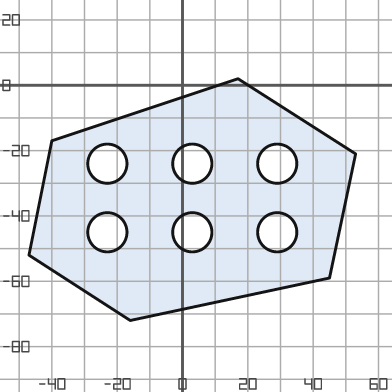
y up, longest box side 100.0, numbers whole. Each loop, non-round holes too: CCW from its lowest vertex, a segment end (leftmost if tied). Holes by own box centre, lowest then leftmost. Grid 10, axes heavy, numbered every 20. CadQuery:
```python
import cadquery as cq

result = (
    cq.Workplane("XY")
    .moveTo(-16.0, -72.0)
    .lineTo(45.0, -59.0)
    .lineTo(53.0, -21.0)
    .lineTo(17.0, 2.0)
    .lineTo(-40.0, -17.0)
    .lineTo(-47.0, -52.0)
    .close()
    .moveTo(-23.0, -45.0)
    .circle(6.0)
    .moveTo(3.0, -45.0)
    .circle(6.0)
    .moveTo(29.0, -45.0)
    .circle(6.0)
    .moveTo(-23.0, -24.0)
    .circle(6.0)
    .moveTo(3.0, -24.0)
    .circle(6.0)
    .moveTo(29.0, -24.0)
    .circle(6.0)
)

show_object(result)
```